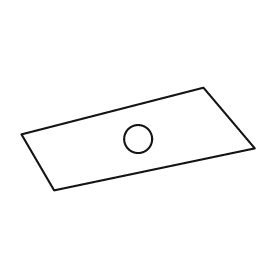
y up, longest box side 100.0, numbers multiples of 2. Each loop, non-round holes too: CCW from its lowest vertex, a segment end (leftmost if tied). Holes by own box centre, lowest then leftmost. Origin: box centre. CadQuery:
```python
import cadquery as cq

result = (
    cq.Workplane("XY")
    .moveTo(-36.0, -22.0)
    .lineTo(50.0, -4.0)
    .lineTo(28.0, 22.0)
    .lineTo(-50.0, 2.0)
    .close()
    .moveTo(0.0, 0.0)
    .circle(6.0)
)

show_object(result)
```